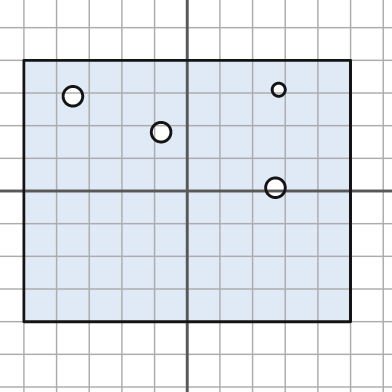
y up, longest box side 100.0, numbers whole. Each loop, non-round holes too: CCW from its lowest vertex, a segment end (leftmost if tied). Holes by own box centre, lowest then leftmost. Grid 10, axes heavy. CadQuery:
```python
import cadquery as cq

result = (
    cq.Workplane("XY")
    .moveTo(-50.0, -40.0)
    .lineTo(50.0, -40.0)
    .lineTo(50.0, 40.0)
    .lineTo(-50.0, 40.0)
    .close()
    .moveTo(27.0, 1.0)
    .circle(3.0)
    .moveTo(-8.0, 18.0)
    .circle(3.0)
    .moveTo(-35.0, 29.0)
    .circle(3.0)
    .moveTo(28.0, 31.0)
    .circle(2.0)
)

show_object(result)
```